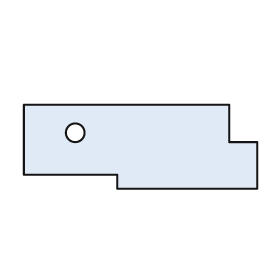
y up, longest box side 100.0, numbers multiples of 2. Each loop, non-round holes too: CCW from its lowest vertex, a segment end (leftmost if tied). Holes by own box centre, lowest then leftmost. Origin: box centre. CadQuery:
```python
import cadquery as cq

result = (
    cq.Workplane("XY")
    .moveTo(-10.0, -18.0)
    .lineTo(50.0, -18.0)
    .lineTo(50.0, 2.0)
    .lineTo(38.0, 2.0)
    .lineTo(38.0, 18.0)
    .lineTo(-50.0, 18.0)
    .lineTo(-50.0, -12.0)
    .lineTo(-10.0, -12.0)
    .close()
    .moveTo(-28.0, 6.0)
    .circle(4.0)
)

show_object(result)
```